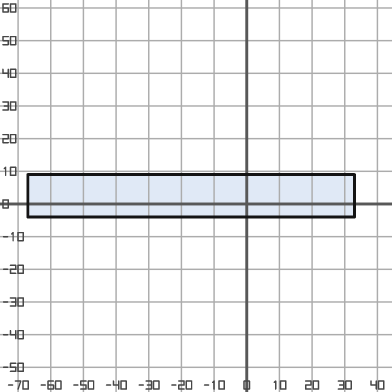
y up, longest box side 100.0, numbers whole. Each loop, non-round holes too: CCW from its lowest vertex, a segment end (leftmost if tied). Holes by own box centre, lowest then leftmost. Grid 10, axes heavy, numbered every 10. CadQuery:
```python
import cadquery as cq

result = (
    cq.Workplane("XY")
    .moveTo(-67.0, -4.0)
    .lineTo(33.0, -4.0)
    .lineTo(33.0, 9.0)
    .lineTo(-67.0, 9.0)
    .close()
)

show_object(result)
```